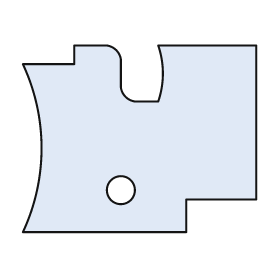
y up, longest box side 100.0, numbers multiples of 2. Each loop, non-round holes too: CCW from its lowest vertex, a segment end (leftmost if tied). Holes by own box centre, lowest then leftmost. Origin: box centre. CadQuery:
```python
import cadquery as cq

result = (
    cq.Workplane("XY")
    .moveTo(-50.0, -40.0)
    .lineTo(20.0, -40.0)
    .lineTo(20.0, -26.0)
    .lineTo(50.0, -26.0)
    .lineTo(50.0, 40.0)
    .lineTo(8.0, 40.0)
    .threePointArc((10.0, 28.0), (8.0, 16.0))
    .lineTo(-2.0, 16.0)
    .threePointArc((-6.0, 18.0), (-8.0, 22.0))
    .lineTo(-8.0, 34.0)
    .threePointArc((-10.0, 38.0), (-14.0, 40.0))
    .lineTo(-28.0, 40.0)
    .lineTo(-28.0, 32.0)
    .lineTo(-50.0, 32.0)
    .threePointArc((-42.0, -4.0), (-50.0, -40.0))
    .close()
    .moveTo(-8.0, -22.0)
    .circle(6.0)
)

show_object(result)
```